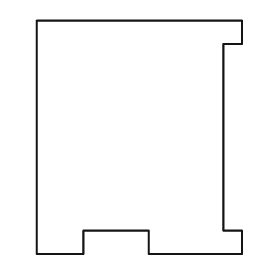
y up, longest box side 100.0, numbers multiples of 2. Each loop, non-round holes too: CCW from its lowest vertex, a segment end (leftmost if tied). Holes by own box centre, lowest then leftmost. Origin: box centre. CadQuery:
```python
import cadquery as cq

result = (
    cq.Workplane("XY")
    .moveTo(-44.0, -50.0)
    .lineTo(-24.0, -50.0)
    .lineTo(-24.0, -40.0)
    .lineTo(4.0, -40.0)
    .lineTo(4.0, -50.0)
    .lineTo(44.0, -50.0)
    .lineTo(44.0, -40.0)
    .lineTo(36.0, -40.0)
    .lineTo(36.0, 40.0)
    .lineTo(44.0, 40.0)
    .lineTo(44.0, 50.0)
    .lineTo(-44.0, 50.0)
    .close()
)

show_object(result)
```